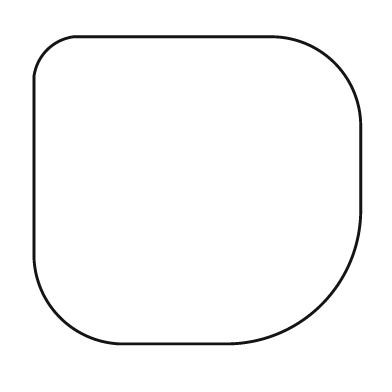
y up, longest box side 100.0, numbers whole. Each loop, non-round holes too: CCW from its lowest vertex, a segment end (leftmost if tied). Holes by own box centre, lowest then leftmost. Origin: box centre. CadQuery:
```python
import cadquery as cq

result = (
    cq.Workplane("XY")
    .moveTo(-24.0, -47.0)
    .lineTo(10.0, -47.0)
    .threePointArc((38.0, -35.0), (50.0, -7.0))
    .lineTo(50.0, 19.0)
    .threePointArc((42.0, 39.0), (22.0, 47.0))
    .lineTo(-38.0, 47.0)
    .threePointArc((-46.0, 43.0), (-50.0, 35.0))
    .lineTo(-50.0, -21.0)
    .threePointArc((-42.0, -39.0), (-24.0, -47.0))
    .close()
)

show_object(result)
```